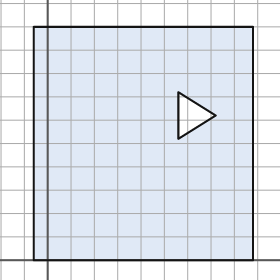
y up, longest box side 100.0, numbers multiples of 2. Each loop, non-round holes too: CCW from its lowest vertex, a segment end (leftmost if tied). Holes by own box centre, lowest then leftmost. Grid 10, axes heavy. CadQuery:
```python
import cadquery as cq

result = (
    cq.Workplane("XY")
    .moveTo(-6.0, 0.0)
    .lineTo(88.0, 0.0)
    .lineTo(88.0, 100.0)
    .lineTo(-6.0, 100.0)
    .close()
    .moveTo(56.0, 52.0)
    .lineTo(72.0, 62.0)
    .lineTo(56.0, 72.0)
    .close()
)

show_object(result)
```